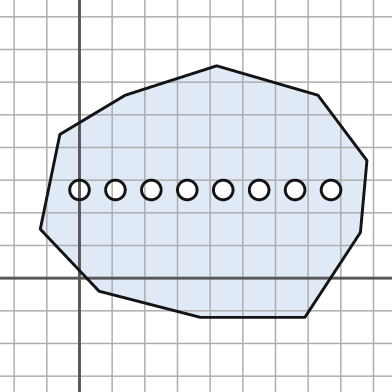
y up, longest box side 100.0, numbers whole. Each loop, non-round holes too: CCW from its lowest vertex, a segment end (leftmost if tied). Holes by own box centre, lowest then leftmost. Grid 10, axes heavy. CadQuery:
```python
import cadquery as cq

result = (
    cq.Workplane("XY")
    .moveTo(37.0, -12.0)
    .lineTo(69.0, -12.0)
    .lineTo(86.0, 14.0)
    .lineTo(88.0, 36.0)
    .lineTo(73.0, 56.0)
    .lineTo(42.0, 65.0)
    .lineTo(14.0, 56.0)
    .lineTo(-6.0, 44.0)
    .lineTo(-12.0, 15.0)
    .lineTo(6.0, -4.0)
    .close()
    .moveTo(0.0, 27.0)
    .circle(3.0)
    .moveTo(11.0, 27.0)
    .circle(3.0)
    .moveTo(22.0, 27.0)
    .circle(3.0)
    .moveTo(33.0, 27.0)
    .circle(3.0)
    .moveTo(44.0, 27.0)
    .circle(3.0)
    .moveTo(55.0, 27.0)
    .circle(3.0)
    .moveTo(66.0, 27.0)
    .circle(3.0)
    .moveTo(77.0, 27.0)
    .circle(3.0)
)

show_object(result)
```